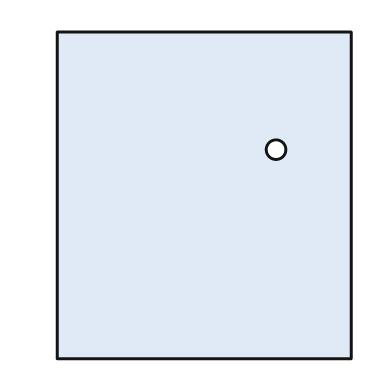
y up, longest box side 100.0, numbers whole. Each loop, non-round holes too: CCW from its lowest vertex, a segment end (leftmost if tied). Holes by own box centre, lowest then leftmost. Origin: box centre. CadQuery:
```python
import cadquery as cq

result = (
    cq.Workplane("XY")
    .moveTo(-45.0, -50.0)
    .lineTo(45.0, -50.0)
    .lineTo(45.0, 50.0)
    .lineTo(-45.0, 50.0)
    .close()
    .moveTo(22.0, 14.0)
    .circle(3.0)
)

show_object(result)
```